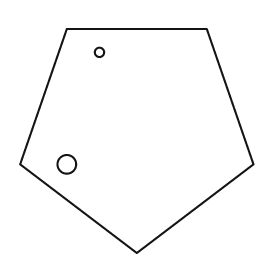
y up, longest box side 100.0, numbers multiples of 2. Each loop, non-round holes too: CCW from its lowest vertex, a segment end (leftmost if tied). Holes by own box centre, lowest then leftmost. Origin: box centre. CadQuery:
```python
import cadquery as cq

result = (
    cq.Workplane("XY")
    .moveTo(0.0, -48.0)
    .lineTo(50.0, -10.0)
    .lineTo(30.0, 48.0)
    .lineTo(-30.0, 48.0)
    .lineTo(-50.0, -10.0)
    .close()
    .moveTo(-30.0, -10.0)
    .circle(4.0)
    .moveTo(-16.0, 38.0)
    .circle(2.0)
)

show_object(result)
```